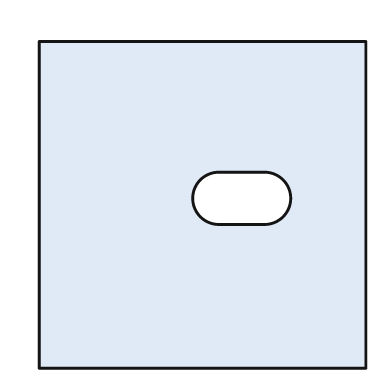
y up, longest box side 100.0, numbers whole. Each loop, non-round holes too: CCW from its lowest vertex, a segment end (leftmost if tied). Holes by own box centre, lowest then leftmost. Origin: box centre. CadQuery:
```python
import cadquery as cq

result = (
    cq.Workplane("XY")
    .moveTo(-50.0, -50.0)
    .lineTo(50.0, -50.0)
    .lineTo(50.0, 50.0)
    .lineTo(-50.0, 50.0)
    .close()
    .moveTo(5.0, -6.0)
    .lineTo(19.0, -6.0)
    .threePointArc((27.0, 2.0), (19.0, 10.0))
    .lineTo(5.0, 10.0)
    .threePointArc((-3.0, 2.0), (5.0, -6.0))
    .close()
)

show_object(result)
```